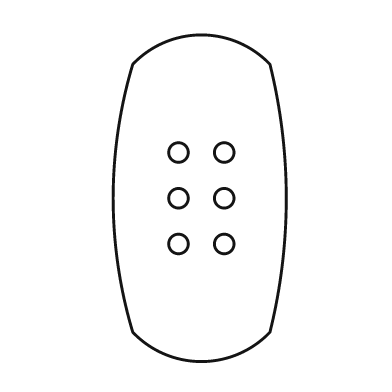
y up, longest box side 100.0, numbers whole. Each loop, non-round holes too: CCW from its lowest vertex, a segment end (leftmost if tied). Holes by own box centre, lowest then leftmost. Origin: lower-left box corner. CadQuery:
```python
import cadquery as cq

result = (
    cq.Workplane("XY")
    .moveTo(6.0, 9.0)
    .threePointArc((27.0, 0.0), (48.0, 9.0))
    .threePointArc((53.0, 50.0), (48.0, 91.0))
    .threePointArc((27.0, 100.0), (6.0, 91.0))
    .threePointArc((0.0, 50.0), (6.0, 9.0))
    .close()
    .moveTo(20.0, 36.0)
    .circle(3.0)
    .moveTo(34.0, 36.0)
    .circle(3.0)
    .moveTo(20.0, 50.0)
    .circle(3.0)
    .moveTo(34.0, 50.0)
    .circle(3.0)
    .moveTo(20.0, 64.0)
    .circle(3.0)
    .moveTo(34.0, 64.0)
    .circle(3.0)
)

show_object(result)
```